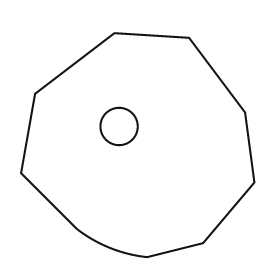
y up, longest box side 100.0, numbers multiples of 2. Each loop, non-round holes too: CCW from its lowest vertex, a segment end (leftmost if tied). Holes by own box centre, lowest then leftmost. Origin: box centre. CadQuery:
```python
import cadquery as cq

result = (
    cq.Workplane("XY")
    .moveTo(4.0, -48.0)
    .lineTo(28.0, -42.0)
    .lineTo(50.0, -16.0)
    .lineTo(46.0, 14.0)
    .lineTo(22.0, 46.0)
    .lineTo(-10.0, 48.0)
    .lineTo(-44.0, 22.0)
    .lineTo(-50.0, -12.0)
    .lineTo(-26.0, -36.0)
    .threePointArc((-12.0, -44.0), (4.0, -48.0))
    .close()
    .moveTo(-8.0, 8.0)
    .circle(8.0)
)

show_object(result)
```